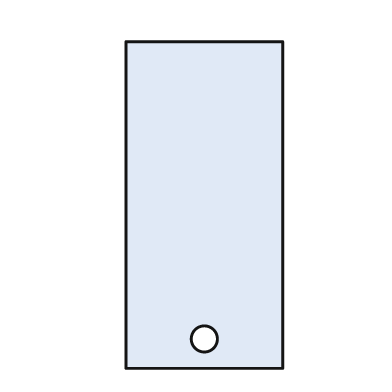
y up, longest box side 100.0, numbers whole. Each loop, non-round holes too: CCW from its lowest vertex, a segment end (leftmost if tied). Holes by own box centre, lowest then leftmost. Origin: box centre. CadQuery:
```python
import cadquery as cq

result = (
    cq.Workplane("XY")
    .moveTo(-24.0, -50.0)
    .lineTo(24.0, -50.0)
    .lineTo(24.0, 50.0)
    .lineTo(-24.0, 50.0)
    .close()
    .moveTo(0.0, -41.0)
    .circle(4.0)
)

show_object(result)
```